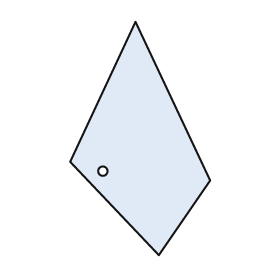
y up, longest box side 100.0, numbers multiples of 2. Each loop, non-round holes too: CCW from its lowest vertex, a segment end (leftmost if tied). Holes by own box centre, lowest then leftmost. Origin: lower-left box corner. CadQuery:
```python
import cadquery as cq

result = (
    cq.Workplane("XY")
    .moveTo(38.0, 0.0)
    .lineTo(60.0, 32.0)
    .lineTo(28.0, 100.0)
    .lineTo(0.0, 40.0)
    .close()
    .moveTo(14.0, 36.0)
    .circle(2.0)
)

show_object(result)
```